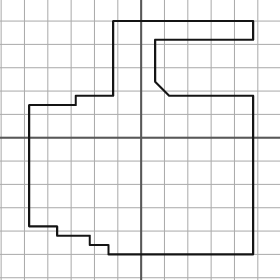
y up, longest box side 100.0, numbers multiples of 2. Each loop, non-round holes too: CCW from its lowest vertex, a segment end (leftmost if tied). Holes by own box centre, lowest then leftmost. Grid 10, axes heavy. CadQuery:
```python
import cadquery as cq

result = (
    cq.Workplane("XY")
    .moveTo(-14.0, -50.0)
    .lineTo(48.0, -50.0)
    .lineTo(48.0, 18.0)
    .lineTo(12.0, 18.0)
    .lineTo(6.0, 24.0)
    .lineTo(6.0, 42.0)
    .lineTo(48.0, 42.0)
    .lineTo(48.0, 50.0)
    .lineTo(-12.0, 50.0)
    .lineTo(-12.0, 18.0)
    .lineTo(-28.0, 18.0)
    .lineTo(-28.0, 14.0)
    .lineTo(-48.0, 14.0)
    .lineTo(-48.0, -38.0)
    .lineTo(-36.0, -38.0)
    .lineTo(-36.0, -42.0)
    .lineTo(-22.0, -42.0)
    .lineTo(-22.0, -46.0)
    .lineTo(-14.0, -46.0)
    .close()
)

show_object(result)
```